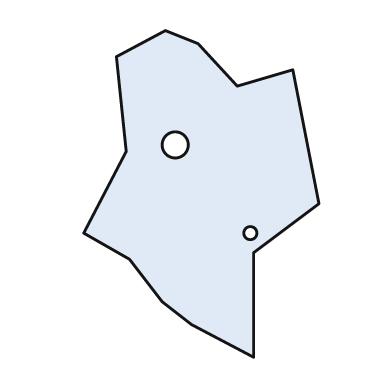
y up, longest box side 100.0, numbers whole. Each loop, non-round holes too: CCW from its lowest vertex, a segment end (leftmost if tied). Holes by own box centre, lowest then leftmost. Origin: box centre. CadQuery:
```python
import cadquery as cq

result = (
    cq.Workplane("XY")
    .moveTo(16.0, -50.0)
    .lineTo(16.0, -18.0)
    .lineTo(36.0, -3.0)
    .lineTo(28.0, 38.0)
    .lineTo(11.0, 33.0)
    .lineTo(-1.0, 46.0)
    .lineTo(-11.0, 50.0)
    .lineTo(-26.0, 42.0)
    .lineTo(-23.0, 13.0)
    .lineTo(-36.0, -12.0)
    .lineTo(-22.0, -20.0)
    .lineTo(-12.0, -33.0)
    .lineTo(-3.0, -40.0)
    .close()
    .moveTo(15.0, -12.0)
    .circle(2.0)
    .moveTo(-8.0, 15.0)
    .circle(4.0)
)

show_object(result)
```